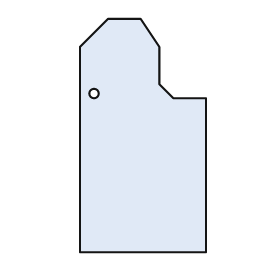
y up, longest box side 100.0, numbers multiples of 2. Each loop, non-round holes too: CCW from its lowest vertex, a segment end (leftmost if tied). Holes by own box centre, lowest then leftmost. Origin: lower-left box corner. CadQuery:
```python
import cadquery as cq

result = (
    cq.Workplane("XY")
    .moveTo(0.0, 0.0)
    .lineTo(54.0, 0.0)
    .lineTo(54.0, 66.0)
    .lineTo(40.0, 66.0)
    .lineTo(34.0, 72.0)
    .lineTo(34.0, 88.0)
    .lineTo(26.0, 100.0)
    .lineTo(12.0, 100.0)
    .lineTo(0.0, 88.0)
    .close()
    .moveTo(6.0, 68.0)
    .circle(2.0)
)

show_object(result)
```